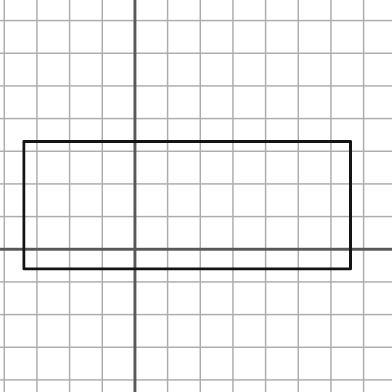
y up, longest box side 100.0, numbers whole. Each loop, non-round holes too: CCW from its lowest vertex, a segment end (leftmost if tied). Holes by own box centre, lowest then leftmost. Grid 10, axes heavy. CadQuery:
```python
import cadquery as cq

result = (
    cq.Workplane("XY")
    .moveTo(-34.0, -6.0)
    .lineTo(66.0, -6.0)
    .lineTo(66.0, 33.0)
    .lineTo(-34.0, 33.0)
    .close()
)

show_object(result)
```